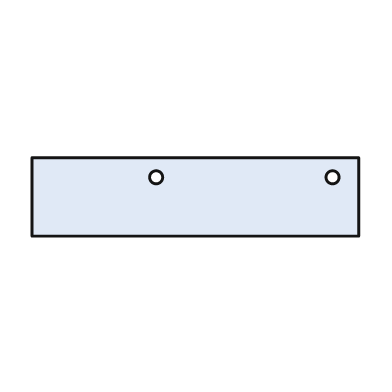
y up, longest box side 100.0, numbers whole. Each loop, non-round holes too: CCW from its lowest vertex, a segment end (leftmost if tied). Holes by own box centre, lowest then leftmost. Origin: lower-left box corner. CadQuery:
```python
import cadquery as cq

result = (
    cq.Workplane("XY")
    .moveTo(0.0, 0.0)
    .lineTo(100.0, 0.0)
    .lineTo(100.0, 24.0)
    .lineTo(0.0, 24.0)
    .close()
    .moveTo(38.0, 18.0)
    .circle(2.0)
    .moveTo(92.0, 18.0)
    .circle(2.0)
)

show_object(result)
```